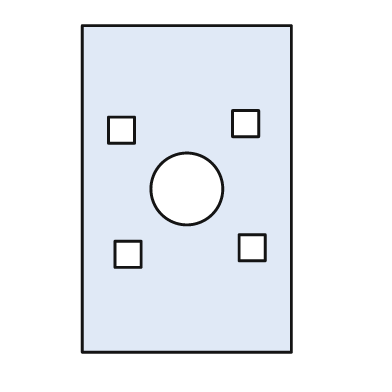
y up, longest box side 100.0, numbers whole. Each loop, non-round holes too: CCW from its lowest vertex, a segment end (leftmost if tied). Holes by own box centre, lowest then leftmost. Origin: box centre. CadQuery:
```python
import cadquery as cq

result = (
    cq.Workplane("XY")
    .moveTo(-32.0, -50.0)
    .lineTo(32.0, -50.0)
    .lineTo(32.0, 50.0)
    .lineTo(-32.0, 50.0)
    .close()
    .moveTo(-22.0, -24.0)
    .lineTo(-14.0, -24.0)
    .lineTo(-14.0, -16.0)
    .lineTo(-22.0, -16.0)
    .close()
    .moveTo(16.0, -22.0)
    .lineTo(24.0, -22.0)
    .lineTo(24.0, -14.0)
    .lineTo(16.0, -14.0)
    .close()
    .moveTo(0.0, 0.0)
    .circle(11.0)
    .moveTo(-24.0, 14.0)
    .lineTo(-16.0, 14.0)
    .lineTo(-16.0, 22.0)
    .lineTo(-24.0, 22.0)
    .close()
    .moveTo(14.0, 16.0)
    .lineTo(22.0, 16.0)
    .lineTo(22.0, 24.0)
    .lineTo(14.0, 24.0)
    .close()
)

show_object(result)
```